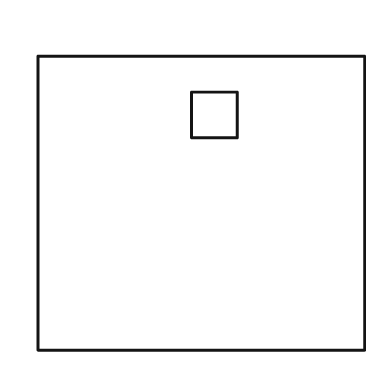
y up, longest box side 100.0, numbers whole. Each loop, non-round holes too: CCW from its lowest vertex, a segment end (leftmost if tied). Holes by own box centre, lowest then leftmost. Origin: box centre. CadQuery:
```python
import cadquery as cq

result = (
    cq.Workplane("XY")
    .moveTo(-50.0, -45.0)
    .lineTo(50.0, -45.0)
    .lineTo(50.0, 45.0)
    .lineTo(-50.0, 45.0)
    .close()
    .moveTo(-3.0, 20.0)
    .lineTo(11.0, 20.0)
    .lineTo(11.0, 34.0)
    .lineTo(-3.0, 34.0)
    .close()
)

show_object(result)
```